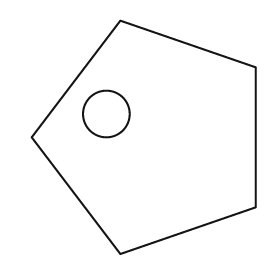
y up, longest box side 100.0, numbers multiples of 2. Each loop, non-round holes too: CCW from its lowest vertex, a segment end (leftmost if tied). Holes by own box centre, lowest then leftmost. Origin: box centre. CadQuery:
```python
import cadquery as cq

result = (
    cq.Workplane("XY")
    .moveTo(-10.0, -50.0)
    .lineTo(48.0, -30.0)
    .lineTo(48.0, 30.0)
    .lineTo(-10.0, 50.0)
    .lineTo(-48.0, 0.0)
    .close()
    .moveTo(-16.0, 10.0)
    .circle(10.0)
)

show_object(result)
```